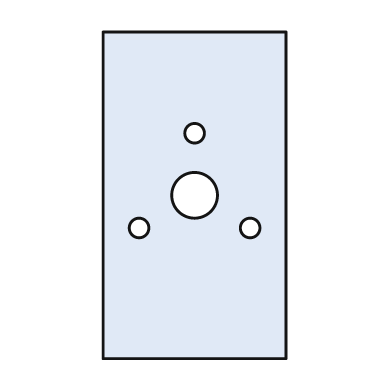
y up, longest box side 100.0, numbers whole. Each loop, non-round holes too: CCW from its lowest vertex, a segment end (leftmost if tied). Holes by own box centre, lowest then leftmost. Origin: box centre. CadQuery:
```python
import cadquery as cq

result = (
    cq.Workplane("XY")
    .moveTo(-28.0, -50.0)
    .lineTo(28.0, -50.0)
    .lineTo(28.0, 50.0)
    .lineTo(-28.0, 50.0)
    .close()
    .moveTo(-17.0, -10.0)
    .circle(3.0)
    .moveTo(17.0, -10.0)
    .circle(3.0)
    .moveTo(0.0, 0.0)
    .circle(7.0)
    .moveTo(0.0, 19.0)
    .circle(3.0)
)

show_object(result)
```